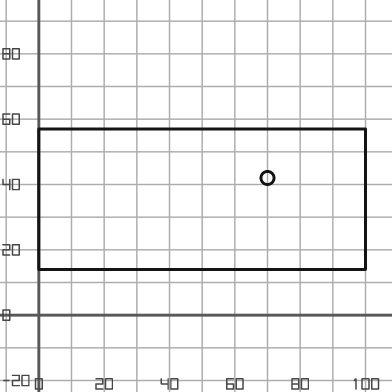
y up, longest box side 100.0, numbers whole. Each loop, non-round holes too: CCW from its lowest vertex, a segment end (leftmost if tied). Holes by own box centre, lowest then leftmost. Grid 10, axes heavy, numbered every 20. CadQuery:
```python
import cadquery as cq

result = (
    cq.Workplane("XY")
    .moveTo(0.0, 14.0)
    .lineTo(100.0, 14.0)
    .lineTo(100.0, 57.0)
    .lineTo(0.0, 57.0)
    .close()
    .moveTo(70.0, 42.0)
    .circle(2.0)
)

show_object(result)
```